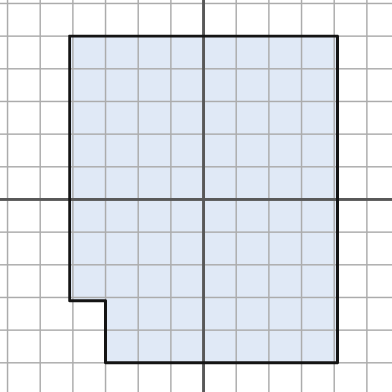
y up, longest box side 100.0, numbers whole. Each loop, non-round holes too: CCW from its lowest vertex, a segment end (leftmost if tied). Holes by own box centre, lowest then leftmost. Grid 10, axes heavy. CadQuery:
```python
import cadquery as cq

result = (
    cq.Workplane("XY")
    .moveTo(-30.0, -50.0)
    .lineTo(41.0, -50.0)
    .lineTo(41.0, 50.0)
    .lineTo(-41.0, 50.0)
    .lineTo(-41.0, -31.0)
    .lineTo(-30.0, -31.0)
    .close()
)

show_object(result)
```